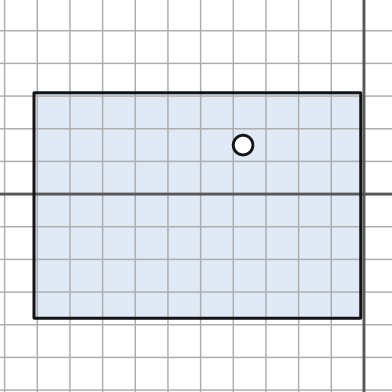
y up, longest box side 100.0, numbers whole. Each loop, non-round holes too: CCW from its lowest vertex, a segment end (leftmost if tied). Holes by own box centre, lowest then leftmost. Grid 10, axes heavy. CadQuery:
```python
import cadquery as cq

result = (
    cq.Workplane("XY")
    .moveTo(-101.0, -38.0)
    .lineTo(-1.0, -38.0)
    .lineTo(-1.0, 31.0)
    .lineTo(-101.0, 31.0)
    .close()
    .moveTo(-37.0, 15.0)
    .circle(3.0)
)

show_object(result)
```